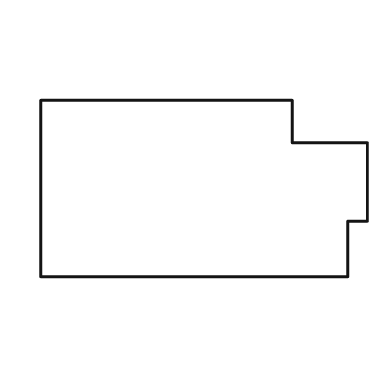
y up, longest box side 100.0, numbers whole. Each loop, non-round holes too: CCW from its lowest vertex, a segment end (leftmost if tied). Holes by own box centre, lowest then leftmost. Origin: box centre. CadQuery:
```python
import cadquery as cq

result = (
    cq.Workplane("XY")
    .moveTo(-50.0, -27.0)
    .lineTo(44.0, -27.0)
    .lineTo(44.0, -10.0)
    .lineTo(50.0, -10.0)
    .lineTo(50.0, 14.0)
    .lineTo(27.0, 14.0)
    .lineTo(27.0, 27.0)
    .lineTo(-50.0, 27.0)
    .close()
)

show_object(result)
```